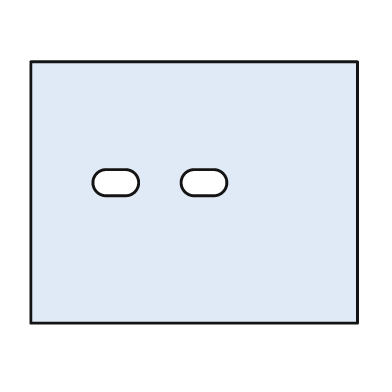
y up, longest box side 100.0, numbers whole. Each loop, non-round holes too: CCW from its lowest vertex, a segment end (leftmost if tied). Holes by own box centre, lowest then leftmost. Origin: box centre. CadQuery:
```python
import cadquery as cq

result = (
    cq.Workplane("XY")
    .moveTo(-50.0, -40.0)
    .lineTo(50.0, -40.0)
    .lineTo(50.0, 40.0)
    .lineTo(-50.0, 40.0)
    .close()
    .moveTo(-27.0, -1.0)
    .lineTo(-21.0, -1.0)
    .threePointArc((-17.0, 3.0), (-21.0, 7.0))
    .lineTo(-27.0, 7.0)
    .threePointArc((-31.0, 3.0), (-27.0, -1.0))
    .close()
    .moveTo(0.0, -1.0)
    .lineTo(6.0, -1.0)
    .threePointArc((10.0, 3.0), (6.0, 7.0))
    .lineTo(0.0, 7.0)
    .threePointArc((-4.0, 3.0), (0.0, -1.0))
    .close()
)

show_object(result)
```